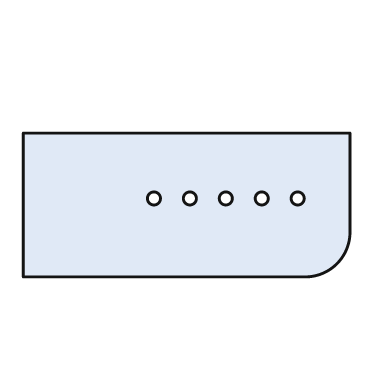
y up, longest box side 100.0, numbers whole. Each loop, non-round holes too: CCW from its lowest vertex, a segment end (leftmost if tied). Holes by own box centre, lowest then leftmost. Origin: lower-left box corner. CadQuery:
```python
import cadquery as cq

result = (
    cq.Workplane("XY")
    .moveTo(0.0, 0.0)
    .lineTo(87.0, 0.0)
    .threePointArc((96.0, 4.0), (100.0, 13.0))
    .lineTo(100.0, 44.0)
    .lineTo(0.0, 44.0)
    .close()
    .moveTo(40.0, 24.0)
    .circle(2.0)
    .moveTo(51.0, 24.0)
    .circle(2.0)
    .moveTo(62.0, 24.0)
    .circle(2.0)
    .moveTo(73.0, 24.0)
    .circle(2.0)
    .moveTo(84.0, 24.0)
    .circle(2.0)
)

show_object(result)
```